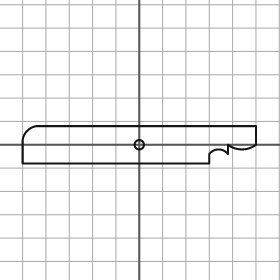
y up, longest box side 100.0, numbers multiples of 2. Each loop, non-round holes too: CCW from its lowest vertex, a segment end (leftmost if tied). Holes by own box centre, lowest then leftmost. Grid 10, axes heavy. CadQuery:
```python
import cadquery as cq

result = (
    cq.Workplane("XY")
    .moveTo(-50.0, -8.0)
    .lineTo(30.0, -8.0)
    .lineTo(30.0, -4.0)
    .threePointArc((34.0, -2.0), (38.0, -4.0))
    .lineTo(38.0, 0.0)
    .threePointArc((44.0, -2.0), (50.0, 0.0))
    .lineTo(50.0, 8.0)
    .lineTo(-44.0, 8.0)
    .threePointArc((-48.0, 6.0), (-50.0, 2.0))
    .close()
    .moveTo(0.0, 0.0)
    .circle(2.0)
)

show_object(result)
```